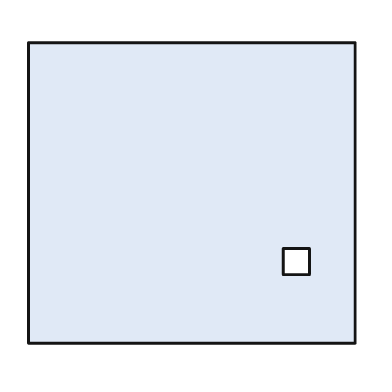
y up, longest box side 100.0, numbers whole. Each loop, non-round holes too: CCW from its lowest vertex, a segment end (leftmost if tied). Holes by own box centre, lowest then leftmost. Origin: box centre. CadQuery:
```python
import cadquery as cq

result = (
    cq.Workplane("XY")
    .moveTo(-50.0, -46.0)
    .lineTo(50.0, -46.0)
    .lineTo(50.0, 46.0)
    .lineTo(-50.0, 46.0)
    .close()
    .moveTo(28.0, -25.0)
    .lineTo(36.0, -25.0)
    .lineTo(36.0, -17.0)
    .lineTo(28.0, -17.0)
    .close()
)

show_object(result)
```